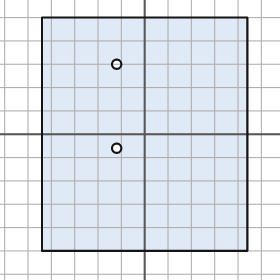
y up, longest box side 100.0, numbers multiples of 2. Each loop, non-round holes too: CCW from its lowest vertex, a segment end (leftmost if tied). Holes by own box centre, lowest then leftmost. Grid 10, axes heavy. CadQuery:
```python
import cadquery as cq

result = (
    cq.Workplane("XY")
    .moveTo(-44.0, -50.0)
    .lineTo(44.0, -50.0)
    .lineTo(44.0, 50.0)
    .lineTo(-44.0, 50.0)
    .close()
    .moveTo(-12.0, -6.0)
    .circle(2.0)
    .moveTo(-12.0, 30.0)
    .circle(2.0)
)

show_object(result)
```